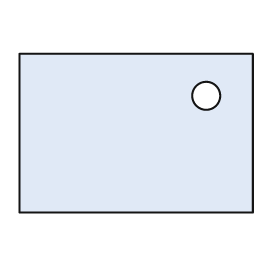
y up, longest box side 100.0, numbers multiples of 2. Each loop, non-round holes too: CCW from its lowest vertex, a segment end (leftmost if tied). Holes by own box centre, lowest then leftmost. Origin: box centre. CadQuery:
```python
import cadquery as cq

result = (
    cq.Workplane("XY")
    .moveTo(-50.0, -34.0)
    .lineTo(50.0, -34.0)
    .lineTo(50.0, 34.0)
    .lineTo(-50.0, 34.0)
    .close()
    .moveTo(30.0, 16.0)
    .circle(6.0)
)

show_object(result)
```